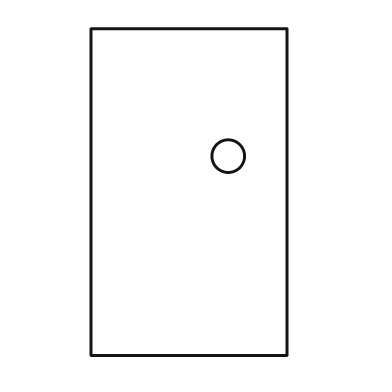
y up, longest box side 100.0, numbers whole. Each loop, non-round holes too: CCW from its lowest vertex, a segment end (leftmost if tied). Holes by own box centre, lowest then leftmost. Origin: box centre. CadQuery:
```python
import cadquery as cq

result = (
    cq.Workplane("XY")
    .moveTo(-30.0, -50.0)
    .lineTo(30.0, -50.0)
    .lineTo(30.0, 50.0)
    .lineTo(-30.0, 50.0)
    .close()
    .moveTo(12.0, 11.0)
    .circle(5.0)
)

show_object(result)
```